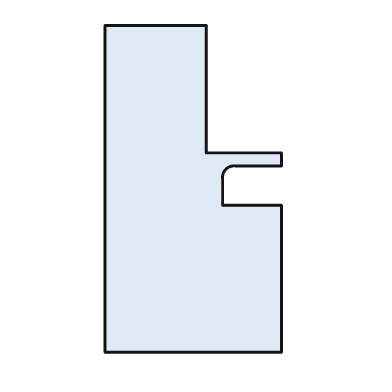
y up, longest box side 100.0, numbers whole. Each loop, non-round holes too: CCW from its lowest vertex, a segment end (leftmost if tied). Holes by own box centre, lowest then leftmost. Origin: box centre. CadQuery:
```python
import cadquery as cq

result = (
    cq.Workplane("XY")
    .moveTo(-27.0, -50.0)
    .lineTo(27.0, -50.0)
    .lineTo(27.0, -5.0)
    .lineTo(9.0, -5.0)
    .lineTo(9.0, 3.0)
    .threePointArc((10.0, 6.0), (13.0, 7.0))
    .lineTo(27.0, 7.0)
    .lineTo(27.0, 11.0)
    .lineTo(4.0, 11.0)
    .lineTo(4.0, 50.0)
    .lineTo(-27.0, 50.0)
    .close()
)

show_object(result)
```